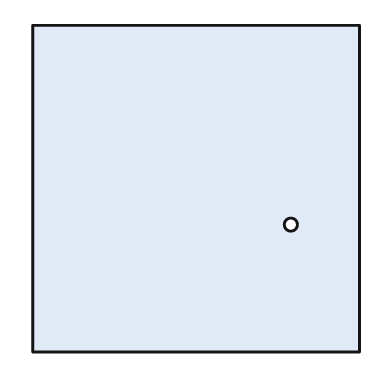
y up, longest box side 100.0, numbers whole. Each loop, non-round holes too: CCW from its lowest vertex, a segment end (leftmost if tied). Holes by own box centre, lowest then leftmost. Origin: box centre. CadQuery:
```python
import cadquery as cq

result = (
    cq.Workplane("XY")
    .moveTo(-50.0, -50.0)
    .lineTo(50.0, -50.0)
    .lineTo(50.0, 50.0)
    .lineTo(-50.0, 50.0)
    .close()
    .moveTo(29.0, -11.0)
    .circle(2.0)
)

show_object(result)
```